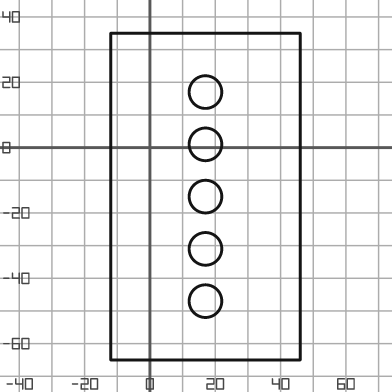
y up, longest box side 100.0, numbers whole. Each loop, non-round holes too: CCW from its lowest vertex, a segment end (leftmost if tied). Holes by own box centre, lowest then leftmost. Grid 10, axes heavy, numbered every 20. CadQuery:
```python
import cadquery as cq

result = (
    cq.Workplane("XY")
    .moveTo(-12.0, -65.0)
    .lineTo(46.0, -65.0)
    .lineTo(46.0, 35.0)
    .lineTo(-12.0, 35.0)
    .close()
    .moveTo(17.0, -47.0)
    .circle(5.0)
    .moveTo(17.0, -31.0)
    .circle(5.0)
    .moveTo(17.0, -15.0)
    .circle(5.0)
    .moveTo(17.0, 1.0)
    .circle(5.0)
    .moveTo(17.0, 17.0)
    .circle(5.0)
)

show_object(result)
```